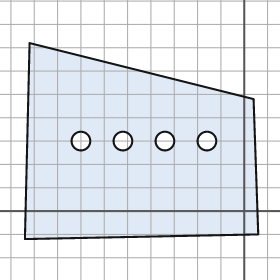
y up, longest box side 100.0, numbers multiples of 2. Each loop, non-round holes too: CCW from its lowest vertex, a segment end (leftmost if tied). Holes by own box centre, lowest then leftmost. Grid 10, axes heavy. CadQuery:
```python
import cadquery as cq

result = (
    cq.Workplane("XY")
    .moveTo(-94.0, -12.0)
    .lineTo(6.0, -10.0)
    .lineTo(4.0, 48.0)
    .lineTo(-92.0, 72.0)
    .close()
    .moveTo(-70.0, 30.0)
    .circle(4.0)
    .moveTo(-52.0, 30.0)
    .circle(4.0)
    .moveTo(-34.0, 30.0)
    .circle(4.0)
    .moveTo(-16.0, 30.0)
    .circle(4.0)
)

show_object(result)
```